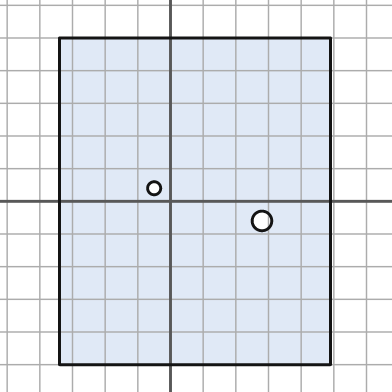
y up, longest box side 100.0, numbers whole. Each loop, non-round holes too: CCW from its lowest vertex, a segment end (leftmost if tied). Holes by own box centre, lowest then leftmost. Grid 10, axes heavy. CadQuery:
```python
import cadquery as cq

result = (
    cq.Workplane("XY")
    .moveTo(-34.0, -50.0)
    .lineTo(49.0, -50.0)
    .lineTo(49.0, 50.0)
    .lineTo(-34.0, 50.0)
    .close()
    .moveTo(28.0, -6.0)
    .circle(3.0)
    .moveTo(-5.0, 4.0)
    .circle(2.0)
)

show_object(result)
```